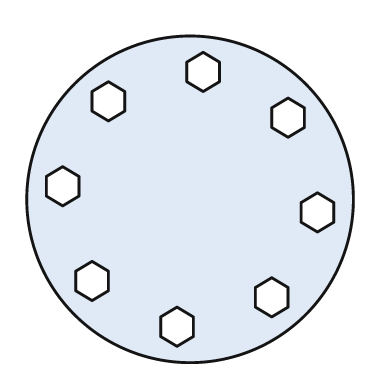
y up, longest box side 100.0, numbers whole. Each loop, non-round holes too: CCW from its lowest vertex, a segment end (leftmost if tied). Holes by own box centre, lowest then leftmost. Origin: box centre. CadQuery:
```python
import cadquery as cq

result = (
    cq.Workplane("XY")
    .moveTo(0.0, 0.0)
    .circle(50.0)
    .moveTo(-4.0, -45.0)
    .lineTo(1.0, -42.0)
    .lineTo(1.0, -36.0)
    .lineTo(-4.0, -33.0)
    .lineTo(-9.0, -36.0)
    .lineTo(-9.0, -42.0)
    .close()
    .moveTo(25.0, -36.0)
    .lineTo(30.0, -33.0)
    .lineTo(30.0, -27.0)
    .lineTo(25.0, -24.0)
    .lineTo(20.0, -27.0)
    .lineTo(20.0, -33.0)
    .close()
    .moveTo(-30.0, -31.0)
    .lineTo(-25.0, -28.0)
    .lineTo(-25.0, -22.0)
    .lineTo(-30.0, -19.0)
    .lineTo(-35.0, -22.0)
    .lineTo(-35.0, -28.0)
    .close()
    .moveTo(39.0, -10.0)
    .lineTo(44.0, -7.0)
    .lineTo(44.0, -1.0)
    .lineTo(39.0, 2.0)
    .lineTo(34.0, -1.0)
    .lineTo(34.0, -7.0)
    .close()
    .moveTo(-39.0, -2.0)
    .lineTo(-34.0, 1.0)
    .lineTo(-34.0, 7.0)
    .lineTo(-39.0, 10.0)
    .lineTo(-44.0, 7.0)
    .lineTo(-44.0, 1.0)
    .close()
    .moveTo(30.0, 19.0)
    .lineTo(35.0, 22.0)
    .lineTo(35.0, 28.0)
    .lineTo(30.0, 31.0)
    .lineTo(25.0, 28.0)
    .lineTo(25.0, 22.0)
    .close()
    .moveTo(-25.0, 24.0)
    .lineTo(-20.0, 27.0)
    .lineTo(-20.0, 33.0)
    .lineTo(-25.0, 36.0)
    .lineTo(-30.0, 33.0)
    .lineTo(-30.0, 27.0)
    .close()
    .moveTo(4.0, 33.0)
    .lineTo(9.0, 36.0)
    .lineTo(9.0, 42.0)
    .lineTo(4.0, 45.0)
    .lineTo(-1.0, 42.0)
    .lineTo(-1.0, 36.0)
    .close()
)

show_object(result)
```